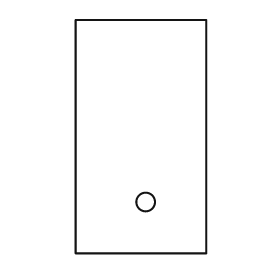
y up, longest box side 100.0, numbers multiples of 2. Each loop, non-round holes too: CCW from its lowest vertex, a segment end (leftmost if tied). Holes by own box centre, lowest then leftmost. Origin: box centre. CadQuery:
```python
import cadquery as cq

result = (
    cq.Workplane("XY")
    .moveTo(-28.0, -50.0)
    .lineTo(28.0, -50.0)
    .lineTo(28.0, 50.0)
    .lineTo(-28.0, 50.0)
    .close()
    .moveTo(2.0, -28.0)
    .circle(4.0)
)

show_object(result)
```